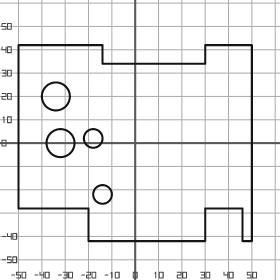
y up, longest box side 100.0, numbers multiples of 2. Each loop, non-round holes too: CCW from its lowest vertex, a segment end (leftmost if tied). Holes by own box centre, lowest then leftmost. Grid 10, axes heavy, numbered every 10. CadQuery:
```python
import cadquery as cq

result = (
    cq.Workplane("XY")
    .moveTo(-20.0, -42.0)
    .lineTo(30.0, -42.0)
    .lineTo(30.0, -28.0)
    .lineTo(46.0, -28.0)
    .lineTo(46.0, -42.0)
    .lineTo(50.0, -42.0)
    .lineTo(50.0, 42.0)
    .lineTo(30.0, 42.0)
    .lineTo(30.0, 34.0)
    .lineTo(-14.0, 34.0)
    .lineTo(-14.0, 42.0)
    .lineTo(-50.0, 42.0)
    .lineTo(-50.0, -28.0)
    .lineTo(-20.0, -28.0)
    .close()
    .moveTo(-14.0, -22.0)
    .circle(4.0)
    .moveTo(-32.0, 0.0)
    .circle(6.0)
    .moveTo(-18.0, 2.0)
    .circle(4.0)
    .moveTo(-34.0, 20.0)
    .circle(6.0)
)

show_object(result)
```